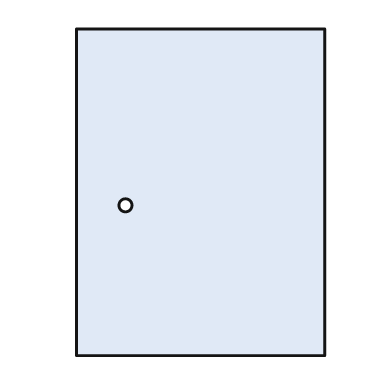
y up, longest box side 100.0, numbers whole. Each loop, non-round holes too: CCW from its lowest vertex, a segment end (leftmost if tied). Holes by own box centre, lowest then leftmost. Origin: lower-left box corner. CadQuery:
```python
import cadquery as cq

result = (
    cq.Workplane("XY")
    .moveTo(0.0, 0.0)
    .lineTo(76.0, 0.0)
    .lineTo(76.0, 100.0)
    .lineTo(0.0, 100.0)
    .close()
    .moveTo(15.0, 46.0)
    .circle(2.0)
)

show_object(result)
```